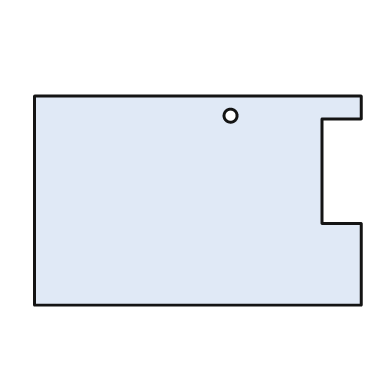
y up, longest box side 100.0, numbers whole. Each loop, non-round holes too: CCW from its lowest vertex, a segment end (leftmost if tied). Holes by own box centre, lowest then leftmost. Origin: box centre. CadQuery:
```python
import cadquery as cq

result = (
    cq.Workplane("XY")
    .moveTo(-50.0, -32.0)
    .lineTo(50.0, -32.0)
    .lineTo(50.0, -7.0)
    .lineTo(38.0, -7.0)
    .lineTo(38.0, 25.0)
    .lineTo(50.0, 25.0)
    .lineTo(50.0, 32.0)
    .lineTo(-50.0, 32.0)
    .close()
    .moveTo(10.0, 26.0)
    .circle(2.0)
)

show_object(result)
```